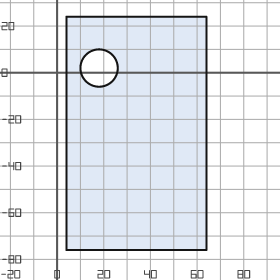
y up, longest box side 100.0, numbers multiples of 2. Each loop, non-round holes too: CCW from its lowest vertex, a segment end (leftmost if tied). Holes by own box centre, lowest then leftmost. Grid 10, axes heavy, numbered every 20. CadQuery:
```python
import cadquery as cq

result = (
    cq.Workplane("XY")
    .moveTo(4.0, -76.0)
    .lineTo(64.0, -76.0)
    .lineTo(64.0, 24.0)
    .lineTo(4.0, 24.0)
    .close()
    .moveTo(18.0, 2.0)
    .circle(8.0)
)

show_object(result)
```